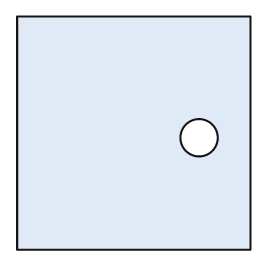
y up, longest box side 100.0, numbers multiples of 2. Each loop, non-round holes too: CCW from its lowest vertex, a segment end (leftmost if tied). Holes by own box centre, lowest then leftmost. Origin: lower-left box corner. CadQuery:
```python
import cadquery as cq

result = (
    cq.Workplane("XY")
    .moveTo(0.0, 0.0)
    .lineTo(100.0, 0.0)
    .lineTo(100.0, 100.0)
    .lineTo(0.0, 100.0)
    .close()
    .moveTo(78.0, 48.0)
    .circle(8.0)
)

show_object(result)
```